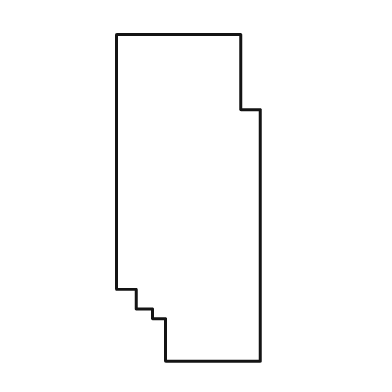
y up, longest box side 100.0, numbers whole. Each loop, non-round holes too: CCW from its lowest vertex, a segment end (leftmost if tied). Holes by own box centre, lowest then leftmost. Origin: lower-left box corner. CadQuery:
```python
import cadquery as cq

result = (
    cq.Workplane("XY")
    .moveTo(15.0, 0.0)
    .lineTo(44.0, 0.0)
    .lineTo(44.0, 77.0)
    .lineTo(38.0, 77.0)
    .lineTo(38.0, 100.0)
    .lineTo(0.0, 100.0)
    .lineTo(0.0, 22.0)
    .lineTo(6.0, 22.0)
    .lineTo(6.0, 16.0)
    .lineTo(11.0, 16.0)
    .lineTo(11.0, 13.0)
    .lineTo(15.0, 13.0)
    .close()
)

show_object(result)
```